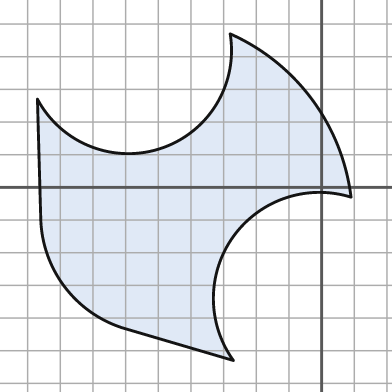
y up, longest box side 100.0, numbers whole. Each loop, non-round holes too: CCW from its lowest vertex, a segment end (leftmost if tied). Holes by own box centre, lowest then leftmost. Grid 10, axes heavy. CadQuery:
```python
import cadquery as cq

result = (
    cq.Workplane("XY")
    .moveTo(-27.0, -53.0)
    .threePointArc((-27.0, -15.0), (9.0, -3.0))
    .threePointArc((-3.0, 27.0), (-28.0, 47.0))
    .threePointArc((-49.0, 12.0), (-87.0, 27.0))
    .lineTo(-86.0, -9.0)
    .threePointArc((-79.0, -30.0), (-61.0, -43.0))
    .close()
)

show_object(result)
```